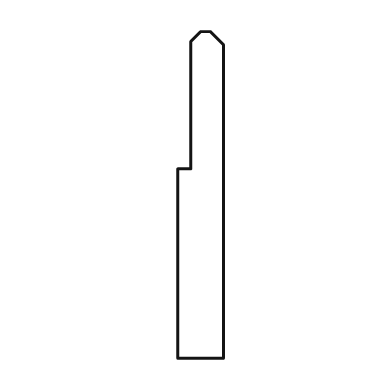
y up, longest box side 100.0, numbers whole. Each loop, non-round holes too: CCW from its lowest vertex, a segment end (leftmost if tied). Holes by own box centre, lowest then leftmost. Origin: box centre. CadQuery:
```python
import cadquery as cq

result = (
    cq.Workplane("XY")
    .moveTo(-7.0, -50.0)
    .lineTo(7.0, -50.0)
    .lineTo(7.0, 46.0)
    .lineTo(3.0, 50.0)
    .lineTo(0.0, 50.0)
    .lineTo(-3.0, 47.0)
    .lineTo(-3.0, 8.0)
    .lineTo(-7.0, 8.0)
    .close()
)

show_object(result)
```